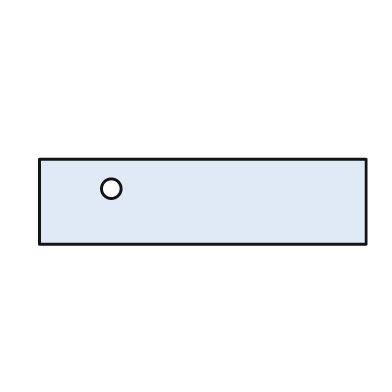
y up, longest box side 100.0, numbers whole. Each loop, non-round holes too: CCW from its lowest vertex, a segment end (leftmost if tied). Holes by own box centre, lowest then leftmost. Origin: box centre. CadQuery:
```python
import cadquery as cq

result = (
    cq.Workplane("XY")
    .moveTo(-50.0, -13.0)
    .lineTo(50.0, -13.0)
    .lineTo(50.0, 13.0)
    .lineTo(-50.0, 13.0)
    .close()
    .moveTo(-28.0, 4.0)
    .circle(3.0)
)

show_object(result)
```